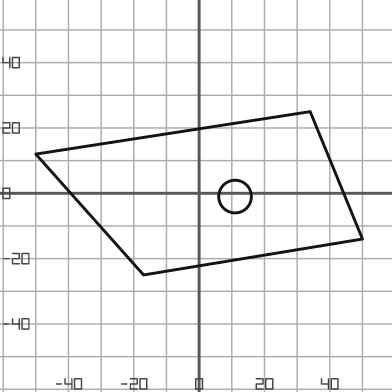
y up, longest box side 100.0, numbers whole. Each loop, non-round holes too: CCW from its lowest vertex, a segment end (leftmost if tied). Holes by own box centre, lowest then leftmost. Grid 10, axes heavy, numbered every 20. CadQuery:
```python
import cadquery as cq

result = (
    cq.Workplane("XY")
    .moveTo(-17.0, -25.0)
    .lineTo(50.0, -14.0)
    .lineTo(34.0, 25.0)
    .lineTo(-50.0, 12.0)
    .close()
    .moveTo(11.0, -1.0)
    .circle(5.0)
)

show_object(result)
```